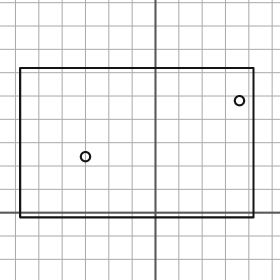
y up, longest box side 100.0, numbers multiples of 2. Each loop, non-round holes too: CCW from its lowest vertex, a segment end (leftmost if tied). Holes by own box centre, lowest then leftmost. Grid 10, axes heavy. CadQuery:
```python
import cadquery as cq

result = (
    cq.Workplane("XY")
    .moveTo(-58.0, -2.0)
    .lineTo(42.0, -2.0)
    .lineTo(42.0, 62.0)
    .lineTo(-58.0, 62.0)
    .close()
    .moveTo(-30.0, 24.0)
    .circle(2.0)
    .moveTo(36.0, 48.0)
    .circle(2.0)
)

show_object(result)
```